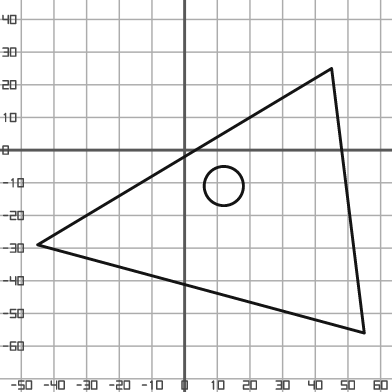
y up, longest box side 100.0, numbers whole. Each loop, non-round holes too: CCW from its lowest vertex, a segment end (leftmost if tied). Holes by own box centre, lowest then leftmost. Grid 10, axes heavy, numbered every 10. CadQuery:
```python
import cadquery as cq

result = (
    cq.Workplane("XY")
    .moveTo(55.0, -56.0)
    .lineTo(45.0, 25.0)
    .lineTo(-45.0, -29.0)
    .close()
    .moveTo(12.0, -11.0)
    .circle(6.0)
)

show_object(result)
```